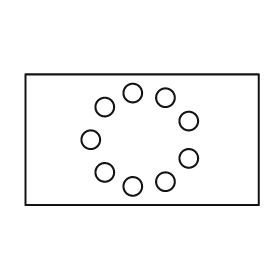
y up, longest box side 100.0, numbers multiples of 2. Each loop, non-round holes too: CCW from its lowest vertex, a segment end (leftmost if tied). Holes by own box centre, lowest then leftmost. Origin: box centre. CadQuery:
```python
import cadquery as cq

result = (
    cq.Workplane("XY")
    .moveTo(-50.0, -28.0)
    .lineTo(50.0, -28.0)
    .lineTo(50.0, 28.0)
    .lineTo(-50.0, 28.0)
    .close()
    .moveTo(-4.0, -20.0)
    .circle(4.0)
    .moveTo(10.0, -18.0)
    .circle(4.0)
    .moveTo(-16.0, -14.0)
    .circle(4.0)
    .moveTo(20.0, -8.0)
    .circle(4.0)
    .moveTo(-22.0, 0.0)
    .circle(4.0)
    .moveTo(20.0, 8.0)
    .circle(4.0)
    .moveTo(-16.0, 14.0)
    .circle(4.0)
    .moveTo(10.0, 18.0)
    .circle(4.0)
    .moveTo(-4.0, 20.0)
    .circle(4.0)
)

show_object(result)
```